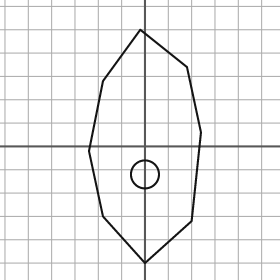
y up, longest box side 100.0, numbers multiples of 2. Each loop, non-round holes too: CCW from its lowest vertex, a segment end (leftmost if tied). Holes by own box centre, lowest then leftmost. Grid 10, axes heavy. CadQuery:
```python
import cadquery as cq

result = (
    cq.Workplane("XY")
    .moveTo(0.0, -50.0)
    .lineTo(20.0, -32.0)
    .lineTo(24.0, 6.0)
    .lineTo(18.0, 34.0)
    .lineTo(-2.0, 50.0)
    .lineTo(-18.0, 28.0)
    .lineTo(-24.0, -2.0)
    .lineTo(-18.0, -30.0)
    .close()
    .moveTo(0.0, -12.0)
    .circle(6.0)
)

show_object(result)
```